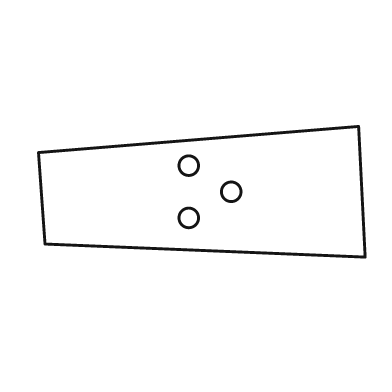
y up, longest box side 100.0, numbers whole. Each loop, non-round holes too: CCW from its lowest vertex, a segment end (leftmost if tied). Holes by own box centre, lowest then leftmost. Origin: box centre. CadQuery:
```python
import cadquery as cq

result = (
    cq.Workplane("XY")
    .moveTo(50.0, -20.0)
    .lineTo(48.0, 20.0)
    .lineTo(-50.0, 12.0)
    .lineTo(-48.0, -16.0)
    .close()
    .moveTo(-4.0, -8.0)
    .circle(3.0)
    .moveTo(9.0, 0.0)
    .circle(3.0)
    .moveTo(-4.0, 8.0)
    .circle(3.0)
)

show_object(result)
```